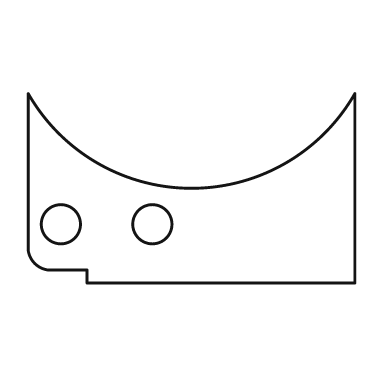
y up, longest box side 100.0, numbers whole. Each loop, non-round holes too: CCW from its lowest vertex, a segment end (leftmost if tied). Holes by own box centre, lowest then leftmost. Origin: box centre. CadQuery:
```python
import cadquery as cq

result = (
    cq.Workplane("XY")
    .moveTo(-32.0, -29.0)
    .lineTo(50.0, -29.0)
    .lineTo(50.0, 29.0)
    .threePointArc((0.0, 0.0), (-50.0, 29.0))
    .lineTo(-50.0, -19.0)
    .threePointArc((-48.0, -23.0), (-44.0, -25.0))
    .lineTo(-32.0, -25.0)
    .close()
    .moveTo(-40.0, -11.0)
    .circle(6.0)
    .moveTo(-12.0, -11.0)
    .circle(6.0)
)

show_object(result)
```